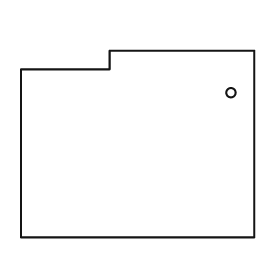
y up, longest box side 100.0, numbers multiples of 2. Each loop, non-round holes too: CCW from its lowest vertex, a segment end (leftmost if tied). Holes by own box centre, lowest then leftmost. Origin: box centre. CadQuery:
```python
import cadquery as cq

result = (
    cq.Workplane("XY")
    .moveTo(-50.0, -40.0)
    .lineTo(50.0, -40.0)
    .lineTo(50.0, 40.0)
    .lineTo(-12.0, 40.0)
    .lineTo(-12.0, 32.0)
    .lineTo(-50.0, 32.0)
    .close()
    .moveTo(40.0, 22.0)
    .circle(2.0)
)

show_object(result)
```